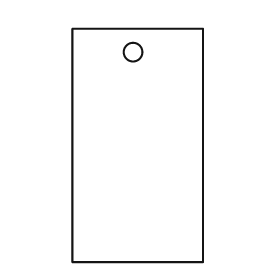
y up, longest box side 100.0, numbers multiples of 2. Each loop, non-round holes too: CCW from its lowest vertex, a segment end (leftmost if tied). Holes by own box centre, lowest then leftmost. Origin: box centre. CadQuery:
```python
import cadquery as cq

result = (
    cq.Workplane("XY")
    .moveTo(-28.0, -50.0)
    .lineTo(28.0, -50.0)
    .lineTo(28.0, 50.0)
    .lineTo(-28.0, 50.0)
    .close()
    .moveTo(-2.0, 40.0)
    .circle(4.0)
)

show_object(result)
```